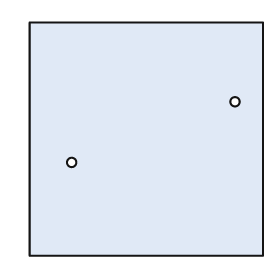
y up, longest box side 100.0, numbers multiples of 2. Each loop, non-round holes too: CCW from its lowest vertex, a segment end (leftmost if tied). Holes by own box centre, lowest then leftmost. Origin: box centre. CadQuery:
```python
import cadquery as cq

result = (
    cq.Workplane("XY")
    .moveTo(-50.0, -50.0)
    .lineTo(50.0, -50.0)
    .lineTo(50.0, 50.0)
    .lineTo(-50.0, 50.0)
    .close()
    .moveTo(-32.0, -10.0)
    .circle(2.0)
    .moveTo(38.0, 16.0)
    .circle(2.0)
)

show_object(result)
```